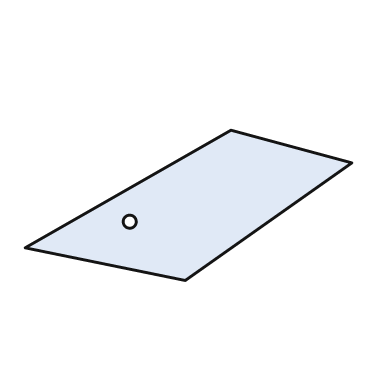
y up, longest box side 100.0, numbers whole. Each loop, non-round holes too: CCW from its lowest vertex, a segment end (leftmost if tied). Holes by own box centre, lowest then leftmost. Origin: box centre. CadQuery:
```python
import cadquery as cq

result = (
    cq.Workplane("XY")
    .moveTo(-1.0, -23.0)
    .lineTo(50.0, 13.0)
    .lineTo(13.0, 23.0)
    .lineTo(-50.0, -13.0)
    .close()
    .moveTo(-18.0, -5.0)
    .circle(2.0)
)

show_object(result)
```